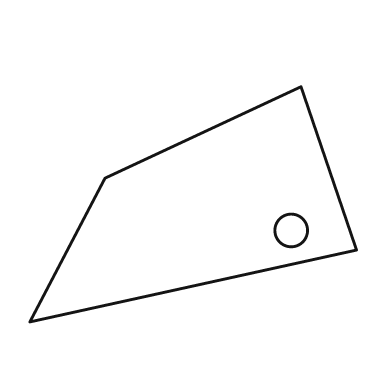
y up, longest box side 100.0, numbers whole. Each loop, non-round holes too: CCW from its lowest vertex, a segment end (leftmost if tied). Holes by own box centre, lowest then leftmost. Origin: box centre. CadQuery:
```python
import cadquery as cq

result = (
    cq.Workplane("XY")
    .moveTo(-50.0, -36.0)
    .lineTo(50.0, -14.0)
    .lineTo(33.0, 36.0)
    .lineTo(-27.0, 8.0)
    .close()
    .moveTo(30.0, -8.0)
    .circle(5.0)
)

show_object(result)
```